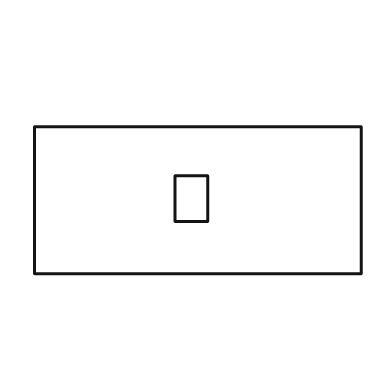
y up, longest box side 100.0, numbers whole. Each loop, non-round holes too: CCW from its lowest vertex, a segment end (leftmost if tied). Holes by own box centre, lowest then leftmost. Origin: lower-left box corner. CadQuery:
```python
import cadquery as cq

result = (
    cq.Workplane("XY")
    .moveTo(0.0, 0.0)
    .lineTo(100.0, 0.0)
    .lineTo(100.0, 45.0)
    .lineTo(0.0, 45.0)
    .close()
    .moveTo(43.0, 16.0)
    .lineTo(53.0, 16.0)
    .lineTo(53.0, 30.0)
    .lineTo(43.0, 30.0)
    .close()
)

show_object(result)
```